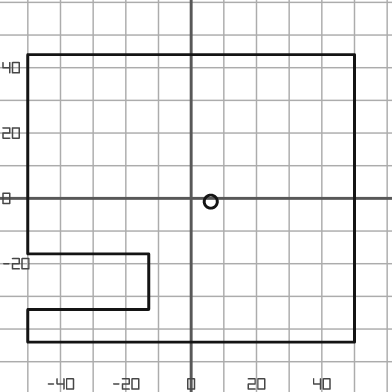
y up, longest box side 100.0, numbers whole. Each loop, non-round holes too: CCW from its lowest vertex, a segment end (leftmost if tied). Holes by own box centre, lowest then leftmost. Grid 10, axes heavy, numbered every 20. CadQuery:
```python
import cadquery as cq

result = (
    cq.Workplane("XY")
    .moveTo(-50.0, -44.0)
    .lineTo(50.0, -44.0)
    .lineTo(50.0, 44.0)
    .lineTo(-50.0, 44.0)
    .lineTo(-50.0, -17.0)
    .lineTo(-13.0, -17.0)
    .lineTo(-13.0, -34.0)
    .lineTo(-50.0, -34.0)
    .close()
    .moveTo(6.0, -1.0)
    .circle(2.0)
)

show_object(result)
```